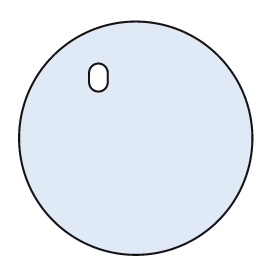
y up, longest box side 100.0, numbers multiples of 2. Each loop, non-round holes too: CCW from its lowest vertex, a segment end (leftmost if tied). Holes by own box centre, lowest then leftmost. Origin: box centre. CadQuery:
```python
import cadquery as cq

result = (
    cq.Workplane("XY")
    .moveTo(0.0, 0.0)
    .circle(50.0)
    .moveTo(-20.0, 24.0)
    .threePointArc((-16.0, 20.0), (-12.0, 24.0))
    .lineTo(-12.0, 28.0)
    .threePointArc((-16.0, 32.0), (-20.0, 28.0))
    .close()
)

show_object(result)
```